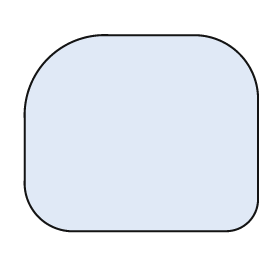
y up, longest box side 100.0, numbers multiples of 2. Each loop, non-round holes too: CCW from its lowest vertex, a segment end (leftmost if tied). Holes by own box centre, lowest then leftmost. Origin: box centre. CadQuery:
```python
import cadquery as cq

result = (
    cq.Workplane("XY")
    .moveTo(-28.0, -42.0)
    .lineTo(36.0, -42.0)
    .threePointArc((46.0, -38.0), (50.0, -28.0))
    .lineTo(50.0, 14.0)
    .threePointArc((42.0, 34.0), (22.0, 42.0))
    .lineTo(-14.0, 42.0)
    .threePointArc((-40.0, 32.0), (-50.0, 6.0))
    .lineTo(-50.0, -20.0)
    .threePointArc((-44.0, -36.0), (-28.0, -42.0))
    .close()
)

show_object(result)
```